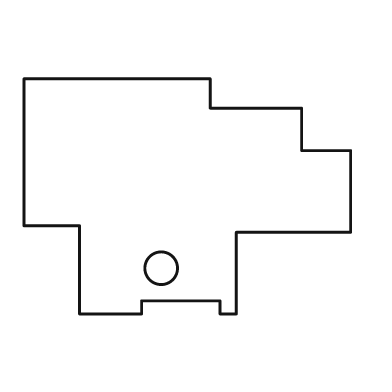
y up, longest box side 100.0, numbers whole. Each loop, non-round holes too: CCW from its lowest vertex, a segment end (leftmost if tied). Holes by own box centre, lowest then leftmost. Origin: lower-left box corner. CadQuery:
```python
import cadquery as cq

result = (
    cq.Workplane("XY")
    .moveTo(17.0, 0.0)
    .lineTo(36.0, 0.0)
    .lineTo(36.0, 4.0)
    .lineTo(60.0, 4.0)
    .lineTo(60.0, 0.0)
    .lineTo(65.0, 0.0)
    .lineTo(65.0, 25.0)
    .lineTo(100.0, 25.0)
    .lineTo(100.0, 50.0)
    .lineTo(85.0, 50.0)
    .lineTo(85.0, 63.0)
    .lineTo(57.0, 63.0)
    .lineTo(57.0, 72.0)
    .lineTo(0.0, 72.0)
    .lineTo(0.0, 27.0)
    .lineTo(17.0, 27.0)
    .close()
    .moveTo(42.0, 14.0)
    .circle(5.0)
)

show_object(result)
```